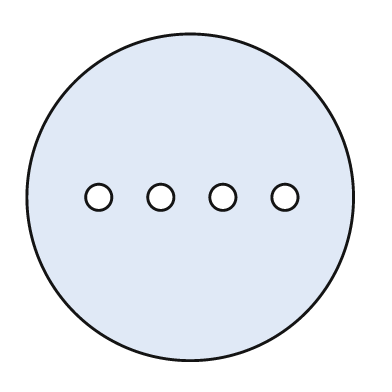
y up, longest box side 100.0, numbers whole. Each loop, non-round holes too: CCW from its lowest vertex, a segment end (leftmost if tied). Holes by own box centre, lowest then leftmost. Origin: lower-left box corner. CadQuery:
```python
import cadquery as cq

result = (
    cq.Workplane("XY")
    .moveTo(50.0, 50.0)
    .circle(50.0)
    .moveTo(22.0, 50.0)
    .circle(4.0)
    .moveTo(41.0, 50.0)
    .circle(4.0)
    .moveTo(60.0, 50.0)
    .circle(4.0)
    .moveTo(79.0, 50.0)
    .circle(4.0)
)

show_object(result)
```